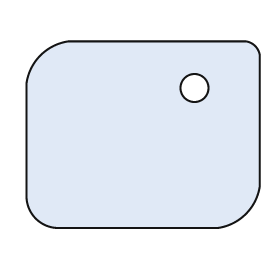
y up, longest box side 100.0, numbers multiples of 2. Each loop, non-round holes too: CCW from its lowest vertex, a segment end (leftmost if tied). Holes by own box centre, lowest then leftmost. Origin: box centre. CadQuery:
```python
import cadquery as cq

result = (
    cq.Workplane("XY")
    .moveTo(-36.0, -40.0)
    .lineTo(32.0, -40.0)
    .threePointArc((44.0, -34.0), (50.0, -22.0))
    .lineTo(50.0, 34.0)
    .threePointArc((48.0, 38.0), (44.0, 40.0))
    .lineTo(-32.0, 40.0)
    .threePointArc((-44.0, 34.0), (-50.0, 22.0))
    .lineTo(-50.0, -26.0)
    .threePointArc((-46.0, -36.0), (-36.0, -40.0))
    .close()
    .moveTo(22.0, 20.0)
    .circle(6.0)
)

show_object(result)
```